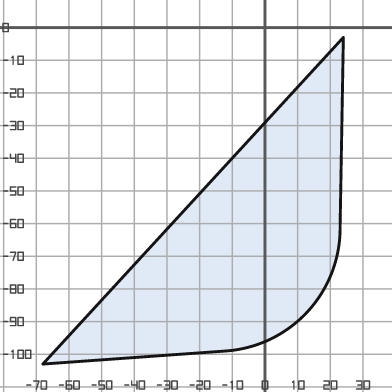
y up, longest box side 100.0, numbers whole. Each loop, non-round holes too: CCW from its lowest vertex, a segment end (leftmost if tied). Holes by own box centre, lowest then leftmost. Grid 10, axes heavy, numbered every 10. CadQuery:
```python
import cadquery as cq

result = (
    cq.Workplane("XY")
    .moveTo(-68.0, -103.0)
    .lineTo(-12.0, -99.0)
    .threePointArc((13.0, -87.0), (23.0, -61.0))
    .lineTo(24.0, -3.0)
    .close()
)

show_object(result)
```